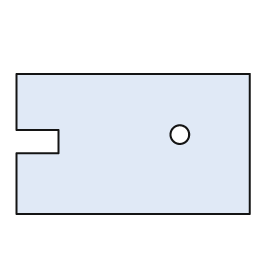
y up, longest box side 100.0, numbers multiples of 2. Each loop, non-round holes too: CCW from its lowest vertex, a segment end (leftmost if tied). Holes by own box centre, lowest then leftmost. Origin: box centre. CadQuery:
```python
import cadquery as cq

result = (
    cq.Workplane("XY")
    .moveTo(-50.0, -30.0)
    .lineTo(50.0, -30.0)
    .lineTo(50.0, 30.0)
    .lineTo(-50.0, 30.0)
    .lineTo(-50.0, 6.0)
    .lineTo(-32.0, 6.0)
    .lineTo(-32.0, -4.0)
    .lineTo(-50.0, -4.0)
    .close()
    .moveTo(20.0, 4.0)
    .circle(4.0)
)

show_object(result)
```